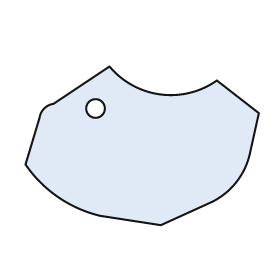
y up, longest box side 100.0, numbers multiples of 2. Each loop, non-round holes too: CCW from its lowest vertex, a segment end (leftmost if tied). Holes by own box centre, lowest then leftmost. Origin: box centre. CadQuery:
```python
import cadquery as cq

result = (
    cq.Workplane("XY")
    .moveTo(8.0, -34.0)
    .lineTo(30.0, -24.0)
    .threePointArc((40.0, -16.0), (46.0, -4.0))
    .lineTo(50.0, 14.0)
    .lineTo(32.0, 28.0)
    .threePointArc((8.0, 22.0), (-14.0, 34.0))
    .lineTo(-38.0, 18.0)
    .threePointArc((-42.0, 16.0), (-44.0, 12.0))
    .lineTo(-50.0, -8.0)
    .threePointArc((-36.0, -22.0), (-18.0, -30.0))
    .close()
    .moveTo(-20.0, 16.0)
    .circle(4.0)
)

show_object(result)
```